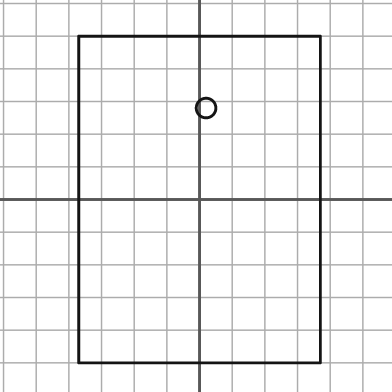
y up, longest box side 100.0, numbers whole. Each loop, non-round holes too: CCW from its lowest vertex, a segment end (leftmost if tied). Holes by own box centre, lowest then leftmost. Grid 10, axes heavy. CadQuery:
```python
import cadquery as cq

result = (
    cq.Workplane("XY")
    .moveTo(-37.0, -50.0)
    .lineTo(37.0, -50.0)
    .lineTo(37.0, 50.0)
    .lineTo(-37.0, 50.0)
    .close()
    .moveTo(2.0, 28.0)
    .circle(3.0)
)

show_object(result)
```